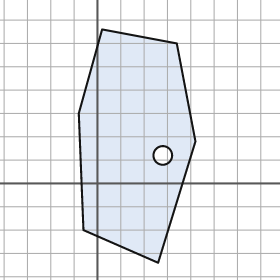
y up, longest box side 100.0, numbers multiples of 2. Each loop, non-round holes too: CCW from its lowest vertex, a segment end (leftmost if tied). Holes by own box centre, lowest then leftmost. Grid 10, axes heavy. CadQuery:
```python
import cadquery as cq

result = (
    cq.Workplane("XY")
    .moveTo(26.0, -34.0)
    .lineTo(42.0, 18.0)
    .lineTo(34.0, 60.0)
    .lineTo(2.0, 66.0)
    .lineTo(-8.0, 30.0)
    .lineTo(-6.0, -20.0)
    .close()
    .moveTo(28.0, 12.0)
    .circle(4.0)
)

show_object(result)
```